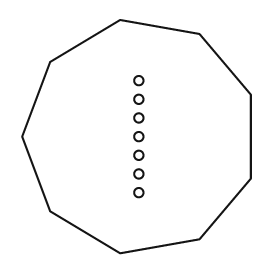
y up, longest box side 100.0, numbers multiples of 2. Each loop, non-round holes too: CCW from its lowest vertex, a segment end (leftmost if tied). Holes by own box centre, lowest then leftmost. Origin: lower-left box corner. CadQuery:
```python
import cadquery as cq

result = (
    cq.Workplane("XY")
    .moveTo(42.0, 0.0)
    .lineTo(76.0, 6.0)
    .lineTo(98.0, 32.0)
    .lineTo(98.0, 68.0)
    .lineTo(76.0, 94.0)
    .lineTo(42.0, 100.0)
    .lineTo(12.0, 82.0)
    .lineTo(0.0, 50.0)
    .lineTo(12.0, 18.0)
    .close()
    .moveTo(50.0, 26.0)
    .circle(2.0)
    .moveTo(50.0, 34.0)
    .circle(2.0)
    .moveTo(50.0, 42.0)
    .circle(2.0)
    .moveTo(50.0, 50.0)
    .circle(2.0)
    .moveTo(50.0, 58.0)
    .circle(2.0)
    .moveTo(50.0, 66.0)
    .circle(2.0)
    .moveTo(50.0, 74.0)
    .circle(2.0)
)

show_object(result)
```